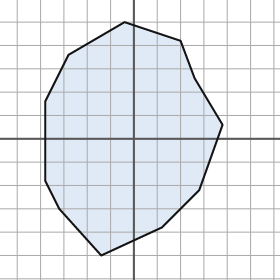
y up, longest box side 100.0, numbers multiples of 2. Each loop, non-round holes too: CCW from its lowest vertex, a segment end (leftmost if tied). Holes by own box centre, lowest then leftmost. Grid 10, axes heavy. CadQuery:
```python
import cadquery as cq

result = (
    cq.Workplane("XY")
    .moveTo(-14.0, -50.0)
    .lineTo(12.0, -38.0)
    .lineTo(28.0, -22.0)
    .lineTo(38.0, 6.0)
    .lineTo(26.0, 26.0)
    .lineTo(20.0, 42.0)
    .lineTo(-4.0, 50.0)
    .lineTo(-28.0, 36.0)
    .lineTo(-38.0, 16.0)
    .lineTo(-38.0, -18.0)
    .lineTo(-32.0, -30.0)
    .close()
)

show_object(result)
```